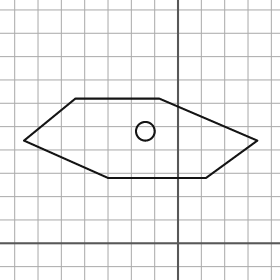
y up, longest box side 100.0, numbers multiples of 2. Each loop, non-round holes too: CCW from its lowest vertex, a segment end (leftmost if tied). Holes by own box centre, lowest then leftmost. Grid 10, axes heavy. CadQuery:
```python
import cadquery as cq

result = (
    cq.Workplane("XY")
    .moveTo(-30.0, 28.0)
    .lineTo(12.0, 28.0)
    .lineTo(34.0, 44.0)
    .lineTo(-8.0, 62.0)
    .lineTo(-44.0, 62.0)
    .lineTo(-66.0, 44.0)
    .close()
    .moveTo(-14.0, 48.0)
    .circle(4.0)
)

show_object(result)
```